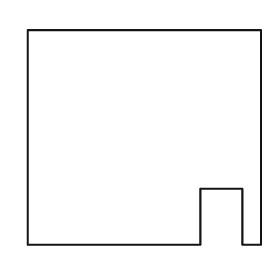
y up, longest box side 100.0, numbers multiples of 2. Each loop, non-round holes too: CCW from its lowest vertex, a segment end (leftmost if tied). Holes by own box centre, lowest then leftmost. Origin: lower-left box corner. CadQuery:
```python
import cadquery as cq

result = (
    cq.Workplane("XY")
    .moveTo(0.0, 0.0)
    .lineTo(74.0, 0.0)
    .lineTo(74.0, 24.0)
    .lineTo(92.0, 24.0)
    .lineTo(92.0, 0.0)
    .lineTo(100.0, 0.0)
    .lineTo(100.0, 92.0)
    .lineTo(0.0, 92.0)
    .close()
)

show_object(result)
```